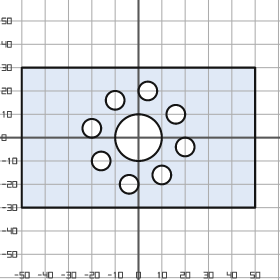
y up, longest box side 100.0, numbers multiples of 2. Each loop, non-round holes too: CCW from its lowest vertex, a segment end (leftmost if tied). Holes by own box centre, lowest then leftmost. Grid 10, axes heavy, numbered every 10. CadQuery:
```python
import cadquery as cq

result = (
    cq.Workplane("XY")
    .moveTo(-50.0, -30.0)
    .lineTo(50.0, -30.0)
    .lineTo(50.0, 30.0)
    .lineTo(-50.0, 30.0)
    .close()
    .moveTo(-4.0, -20.0)
    .circle(4.0)
    .moveTo(10.0, -16.0)
    .circle(4.0)
    .moveTo(-16.0, -10.0)
    .circle(4.0)
    .moveTo(20.0, -4.0)
    .circle(4.0)
    .moveTo(0.0, 0.0)
    .circle(10.0)
    .moveTo(-20.0, 4.0)
    .circle(4.0)
    .moveTo(16.0, 10.0)
    .circle(4.0)
    .moveTo(-10.0, 16.0)
    .circle(4.0)
    .moveTo(4.0, 20.0)
    .circle(4.0)
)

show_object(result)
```